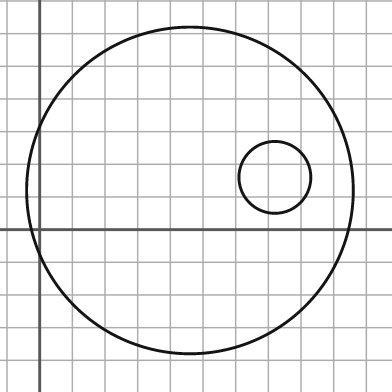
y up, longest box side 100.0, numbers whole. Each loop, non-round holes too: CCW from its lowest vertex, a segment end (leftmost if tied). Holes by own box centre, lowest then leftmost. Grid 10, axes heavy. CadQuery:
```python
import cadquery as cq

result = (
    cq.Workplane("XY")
    .moveTo(46.0, 12.0)
    .circle(50.0)
    .moveTo(72.0, 16.0)
    .circle(11.0)
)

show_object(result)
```